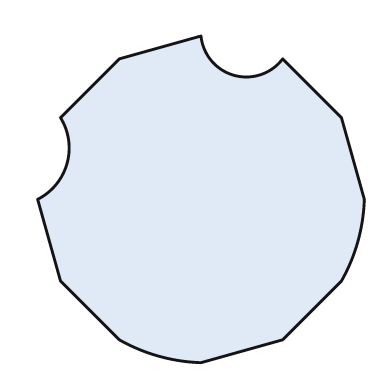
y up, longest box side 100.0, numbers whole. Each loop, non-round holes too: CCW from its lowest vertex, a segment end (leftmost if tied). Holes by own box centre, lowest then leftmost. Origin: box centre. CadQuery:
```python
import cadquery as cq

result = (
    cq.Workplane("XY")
    .moveTo(0.0, -50.0)
    .lineTo(25.0, -43.0)
    .lineTo(43.0, -25.0)
    .threePointArc((48.0, -13.0), (50.0, 0.0))
    .lineTo(43.0, 25.0)
    .lineTo(25.0, 43.0)
    .threePointArc((10.0, 38.0), (0.0, 50.0))
    .lineTo(-25.0, 43.0)
    .lineTo(-43.0, 25.0)
    .threePointArc((-41.0, 11.0), (-50.0, 0.0))
    .lineTo(-43.0, -25.0)
    .lineTo(-25.0, -43.0)
    .threePointArc((-13.0, -48.0), (0.0, -50.0))
    .close()
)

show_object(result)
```